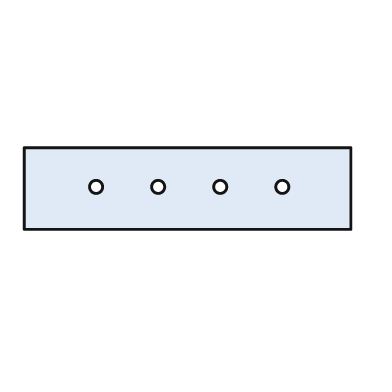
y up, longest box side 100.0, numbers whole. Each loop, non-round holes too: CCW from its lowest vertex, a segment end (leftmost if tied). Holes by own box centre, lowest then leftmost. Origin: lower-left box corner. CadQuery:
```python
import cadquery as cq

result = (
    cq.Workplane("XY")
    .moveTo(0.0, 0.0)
    .lineTo(100.0, 0.0)
    .lineTo(100.0, 25.0)
    .lineTo(0.0, 25.0)
    .close()
    .moveTo(22.0, 13.0)
    .circle(2.0)
    .moveTo(41.0, 13.0)
    .circle(2.0)
    .moveTo(60.0, 13.0)
    .circle(2.0)
    .moveTo(79.0, 13.0)
    .circle(2.0)
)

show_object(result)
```